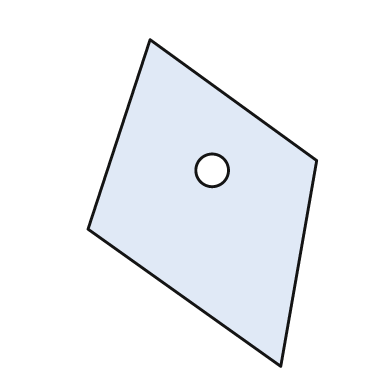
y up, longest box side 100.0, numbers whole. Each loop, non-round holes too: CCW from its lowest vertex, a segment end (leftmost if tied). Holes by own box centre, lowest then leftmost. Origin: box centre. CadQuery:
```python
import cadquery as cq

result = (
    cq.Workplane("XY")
    .moveTo(24.0, -50.0)
    .lineTo(35.0, 13.0)
    .lineTo(-16.0, 50.0)
    .lineTo(-35.0, -8.0)
    .close()
    .moveTo(3.0, 10.0)
    .circle(5.0)
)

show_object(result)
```